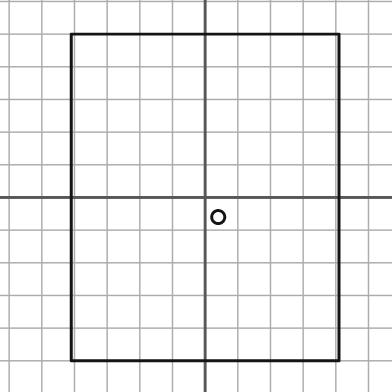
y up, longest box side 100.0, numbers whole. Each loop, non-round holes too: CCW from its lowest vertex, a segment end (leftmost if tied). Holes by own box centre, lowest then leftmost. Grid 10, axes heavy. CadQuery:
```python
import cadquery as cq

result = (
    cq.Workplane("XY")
    .moveTo(-41.0, -50.0)
    .lineTo(41.0, -50.0)
    .lineTo(41.0, 50.0)
    .lineTo(-41.0, 50.0)
    .close()
    .moveTo(4.0, -6.0)
    .circle(2.0)
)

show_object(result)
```